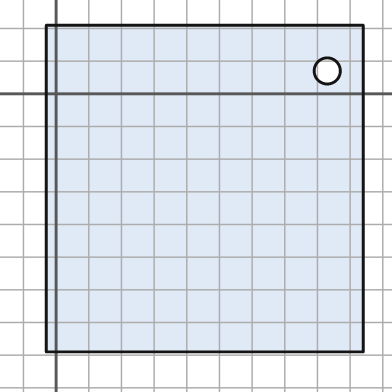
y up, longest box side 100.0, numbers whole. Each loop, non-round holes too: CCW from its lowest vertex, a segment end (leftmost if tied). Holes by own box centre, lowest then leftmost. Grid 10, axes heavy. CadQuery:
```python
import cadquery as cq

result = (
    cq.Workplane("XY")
    .moveTo(-3.0, -79.0)
    .lineTo(94.0, -79.0)
    .lineTo(94.0, 21.0)
    .lineTo(-3.0, 21.0)
    .close()
    .moveTo(83.0, 7.0)
    .circle(4.0)
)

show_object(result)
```